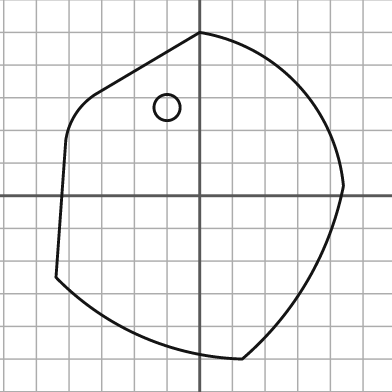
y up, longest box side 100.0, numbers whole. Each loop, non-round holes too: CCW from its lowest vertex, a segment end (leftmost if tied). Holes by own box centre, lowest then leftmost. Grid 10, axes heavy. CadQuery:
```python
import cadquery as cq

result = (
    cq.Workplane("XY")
    .moveTo(13.0, -50.0)
    .threePointArc((33.0, -26.0), (44.0, 3.0))
    .threePointArc((30.0, 34.0), (0.0, 50.0))
    .lineTo(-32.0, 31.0)
    .threePointArc((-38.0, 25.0), (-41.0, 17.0))
    .lineTo(-44.0, -25.0)
    .threePointArc((-18.0, -43.0), (13.0, -50.0))
    .close()
    .moveTo(-10.0, 27.0)
    .circle(4.0)
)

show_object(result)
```